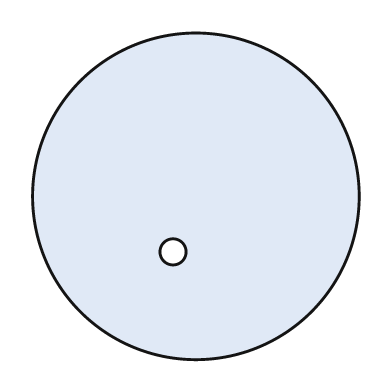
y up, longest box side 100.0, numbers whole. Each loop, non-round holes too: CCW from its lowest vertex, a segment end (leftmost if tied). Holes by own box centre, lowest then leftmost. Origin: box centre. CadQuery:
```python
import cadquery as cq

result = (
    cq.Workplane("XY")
    .moveTo(0.0, 0.0)
    .circle(50.0)
    .moveTo(-7.0, -17.0)
    .circle(4.0)
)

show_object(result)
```